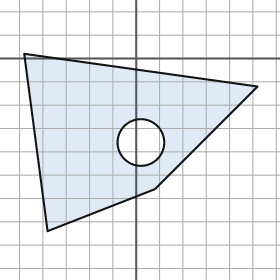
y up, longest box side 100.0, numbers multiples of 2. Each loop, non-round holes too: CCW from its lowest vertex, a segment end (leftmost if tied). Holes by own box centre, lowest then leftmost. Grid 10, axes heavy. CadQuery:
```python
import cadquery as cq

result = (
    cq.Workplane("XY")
    .moveTo(-38.0, -74.0)
    .lineTo(8.0, -56.0)
    .lineTo(52.0, -12.0)
    .lineTo(-48.0, 2.0)
    .close()
    .moveTo(2.0, -36.0)
    .circle(10.0)
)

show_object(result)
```